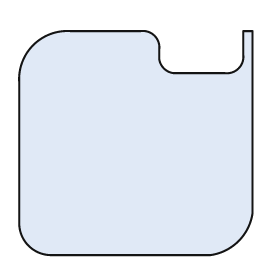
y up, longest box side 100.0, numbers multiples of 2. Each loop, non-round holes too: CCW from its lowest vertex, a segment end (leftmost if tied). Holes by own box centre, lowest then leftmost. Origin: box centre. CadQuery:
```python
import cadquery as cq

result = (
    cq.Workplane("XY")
    .moveTo(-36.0, -48.0)
    .lineTo(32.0, -48.0)
    .threePointArc((44.0, -42.0), (50.0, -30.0))
    .lineTo(50.0, 48.0)
    .lineTo(46.0, 48.0)
    .lineTo(46.0, 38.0)
    .threePointArc((44.0, 32.0), (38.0, 30.0))
    .lineTo(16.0, 30.0)
    .threePointArc((12.0, 32.0), (10.0, 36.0))
    .lineTo(10.0, 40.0)
    .threePointArc((8.0, 46.0), (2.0, 48.0))
    .lineTo(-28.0, 48.0)
    .threePointArc((-44.0, 42.0), (-50.0, 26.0))
    .lineTo(-50.0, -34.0)
    .threePointArc((-46.0, -44.0), (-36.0, -48.0))
    .close()
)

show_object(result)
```